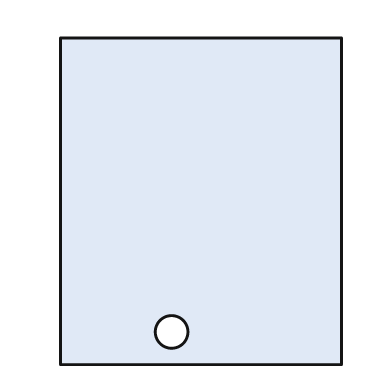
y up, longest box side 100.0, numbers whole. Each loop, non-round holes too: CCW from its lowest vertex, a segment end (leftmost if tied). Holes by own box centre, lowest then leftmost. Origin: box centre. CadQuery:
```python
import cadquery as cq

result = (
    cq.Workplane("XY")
    .moveTo(-43.0, -50.0)
    .lineTo(43.0, -50.0)
    .lineTo(43.0, 50.0)
    .lineTo(-43.0, 50.0)
    .close()
    .moveTo(-9.0, -40.0)
    .circle(5.0)
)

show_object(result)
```